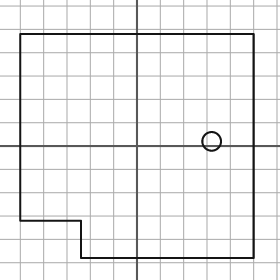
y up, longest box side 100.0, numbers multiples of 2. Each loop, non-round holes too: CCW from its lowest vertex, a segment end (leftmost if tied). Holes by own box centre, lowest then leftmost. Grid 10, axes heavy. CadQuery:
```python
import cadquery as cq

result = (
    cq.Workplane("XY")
    .moveTo(-24.0, -48.0)
    .lineTo(50.0, -48.0)
    .lineTo(50.0, 48.0)
    .lineTo(-50.0, 48.0)
    .lineTo(-50.0, -32.0)
    .lineTo(-24.0, -32.0)
    .close()
    .moveTo(32.0, 2.0)
    .circle(4.0)
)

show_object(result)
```